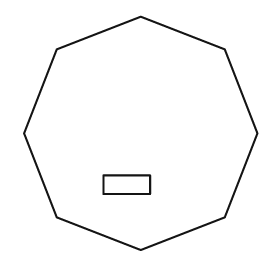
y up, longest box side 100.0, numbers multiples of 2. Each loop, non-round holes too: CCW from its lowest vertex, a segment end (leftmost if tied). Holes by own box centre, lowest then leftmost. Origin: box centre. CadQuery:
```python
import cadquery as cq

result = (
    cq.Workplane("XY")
    .moveTo(0.0, -50.0)
    .lineTo(36.0, -36.0)
    .lineTo(50.0, 0.0)
    .lineTo(36.0, 36.0)
    .lineTo(0.0, 50.0)
    .lineTo(-36.0, 36.0)
    .lineTo(-50.0, 0.0)
    .lineTo(-36.0, -36.0)
    .close()
    .moveTo(-16.0, -26.0)
    .lineTo(4.0, -26.0)
    .lineTo(4.0, -18.0)
    .lineTo(-16.0, -18.0)
    .close()
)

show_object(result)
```